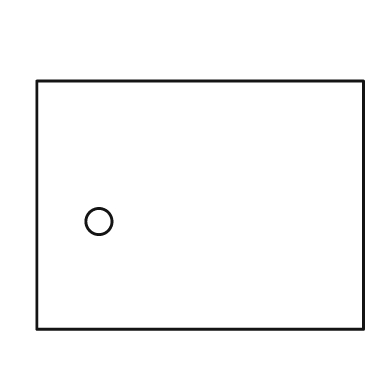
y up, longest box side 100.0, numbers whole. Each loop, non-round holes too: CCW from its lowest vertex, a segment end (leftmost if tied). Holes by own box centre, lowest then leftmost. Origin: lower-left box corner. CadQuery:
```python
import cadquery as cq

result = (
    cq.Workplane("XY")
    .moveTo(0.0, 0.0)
    .lineTo(100.0, 0.0)
    .lineTo(100.0, 76.0)
    .lineTo(0.0, 76.0)
    .close()
    .moveTo(19.0, 33.0)
    .circle(4.0)
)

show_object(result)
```